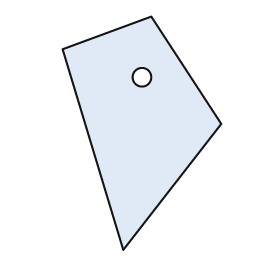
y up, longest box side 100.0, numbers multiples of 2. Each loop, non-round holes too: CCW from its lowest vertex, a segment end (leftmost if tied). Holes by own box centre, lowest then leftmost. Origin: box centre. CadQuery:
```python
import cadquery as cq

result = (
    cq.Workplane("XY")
    .moveTo(-8.0, -50.0)
    .lineTo(34.0, 4.0)
    .lineTo(4.0, 50.0)
    .lineTo(-34.0, 36.0)
    .close()
    .moveTo(0.0, 24.0)
    .circle(4.0)
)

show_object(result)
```